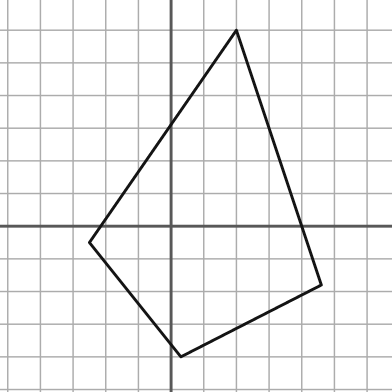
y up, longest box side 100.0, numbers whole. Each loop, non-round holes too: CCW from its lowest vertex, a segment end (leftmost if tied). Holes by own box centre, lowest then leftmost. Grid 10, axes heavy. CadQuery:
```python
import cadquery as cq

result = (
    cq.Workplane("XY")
    .moveTo(3.0, -40.0)
    .lineTo(46.0, -18.0)
    .lineTo(20.0, 60.0)
    .lineTo(-25.0, -5.0)
    .close()
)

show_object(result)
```